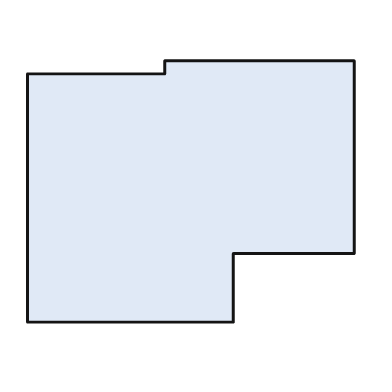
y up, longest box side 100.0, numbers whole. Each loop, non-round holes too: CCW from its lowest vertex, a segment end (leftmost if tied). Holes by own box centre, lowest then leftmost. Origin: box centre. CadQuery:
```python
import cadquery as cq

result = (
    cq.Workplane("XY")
    .moveTo(-50.0, -40.0)
    .lineTo(13.0, -40.0)
    .lineTo(13.0, -19.0)
    .lineTo(50.0, -19.0)
    .lineTo(50.0, 40.0)
    .lineTo(-8.0, 40.0)
    .lineTo(-8.0, 36.0)
    .lineTo(-50.0, 36.0)
    .close()
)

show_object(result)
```